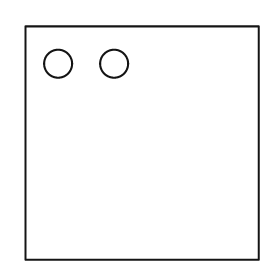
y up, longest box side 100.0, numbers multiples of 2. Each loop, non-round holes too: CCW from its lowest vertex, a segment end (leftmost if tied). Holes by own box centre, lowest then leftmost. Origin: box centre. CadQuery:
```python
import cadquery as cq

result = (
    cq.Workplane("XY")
    .moveTo(-50.0, -50.0)
    .lineTo(50.0, -50.0)
    .lineTo(50.0, 50.0)
    .lineTo(-50.0, 50.0)
    .close()
    .moveTo(-36.0, 34.0)
    .circle(6.0)
    .moveTo(-12.0, 34.0)
    .circle(6.0)
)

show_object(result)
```